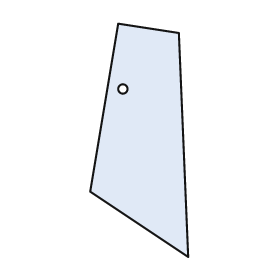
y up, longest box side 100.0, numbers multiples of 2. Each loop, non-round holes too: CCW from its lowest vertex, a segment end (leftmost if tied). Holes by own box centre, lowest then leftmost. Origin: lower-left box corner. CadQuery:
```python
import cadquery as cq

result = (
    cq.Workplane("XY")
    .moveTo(42.0, 0.0)
    .lineTo(38.0, 96.0)
    .lineTo(12.0, 100.0)
    .lineTo(0.0, 28.0)
    .close()
    .moveTo(14.0, 72.0)
    .circle(2.0)
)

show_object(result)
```